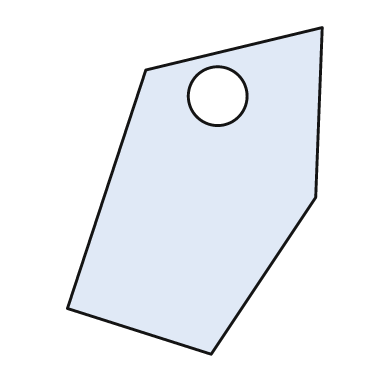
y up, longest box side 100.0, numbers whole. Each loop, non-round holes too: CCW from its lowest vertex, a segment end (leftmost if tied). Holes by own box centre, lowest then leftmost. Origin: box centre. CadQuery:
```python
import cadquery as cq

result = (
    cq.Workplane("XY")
    .moveTo(5.0, -50.0)
    .lineTo(37.0, -2.0)
    .lineTo(39.0, 50.0)
    .lineTo(-15.0, 37.0)
    .lineTo(-39.0, -36.0)
    .close()
    .moveTo(7.0, 29.0)
    .circle(9.0)
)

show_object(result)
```